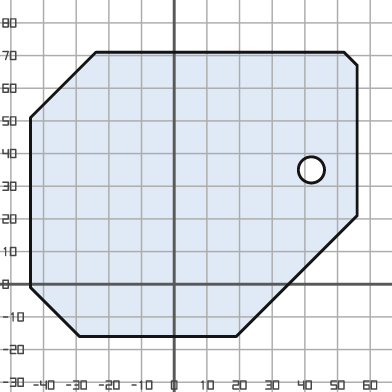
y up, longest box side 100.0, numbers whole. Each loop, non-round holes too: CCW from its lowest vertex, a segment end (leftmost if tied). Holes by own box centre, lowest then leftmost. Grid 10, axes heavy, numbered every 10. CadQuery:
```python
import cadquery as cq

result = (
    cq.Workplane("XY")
    .moveTo(-29.0, -16.0)
    .lineTo(19.0, -16.0)
    .lineTo(56.0, 21.0)
    .lineTo(56.0, 67.0)
    .lineTo(52.0, 71.0)
    .lineTo(-24.0, 71.0)
    .lineTo(-44.0, 51.0)
    .lineTo(-44.0, -1.0)
    .close()
    .moveTo(42.0, 35.0)
    .circle(4.0)
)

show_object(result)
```